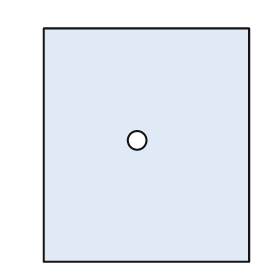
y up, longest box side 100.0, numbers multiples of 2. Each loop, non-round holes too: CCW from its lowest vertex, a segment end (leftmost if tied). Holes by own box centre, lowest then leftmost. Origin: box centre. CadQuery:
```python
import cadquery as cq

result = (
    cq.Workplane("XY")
    .moveTo(-44.0, -50.0)
    .lineTo(44.0, -50.0)
    .lineTo(44.0, 50.0)
    .lineTo(-44.0, 50.0)
    .close()
    .moveTo(-4.0, 2.0)
    .circle(4.0)
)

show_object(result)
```